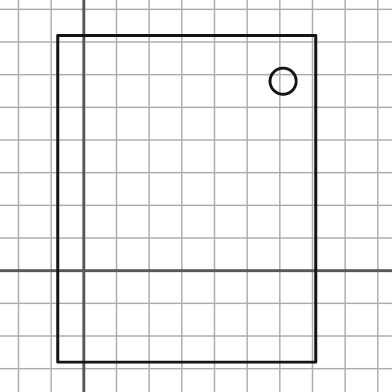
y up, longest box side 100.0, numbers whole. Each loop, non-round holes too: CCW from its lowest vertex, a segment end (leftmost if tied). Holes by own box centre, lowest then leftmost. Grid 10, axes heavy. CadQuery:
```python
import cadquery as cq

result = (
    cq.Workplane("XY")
    .moveTo(-8.0, -28.0)
    .lineTo(71.0, -28.0)
    .lineTo(71.0, 72.0)
    .lineTo(-8.0, 72.0)
    .close()
    .moveTo(61.0, 58.0)
    .circle(4.0)
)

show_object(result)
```